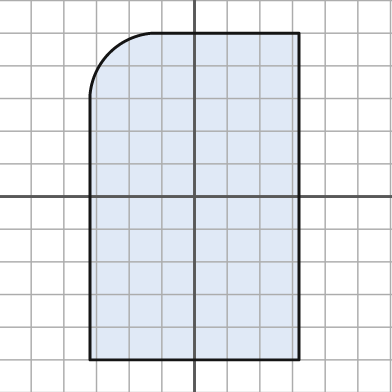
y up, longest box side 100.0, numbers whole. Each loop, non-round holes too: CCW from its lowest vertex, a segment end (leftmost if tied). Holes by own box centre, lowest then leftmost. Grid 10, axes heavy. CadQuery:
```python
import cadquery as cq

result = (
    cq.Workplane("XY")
    .moveTo(-32.0, -50.0)
    .lineTo(32.0, -50.0)
    .lineTo(32.0, 50.0)
    .lineTo(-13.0, 50.0)
    .threePointArc((-26.0, 44.0), (-32.0, 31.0))
    .close()
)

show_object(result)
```